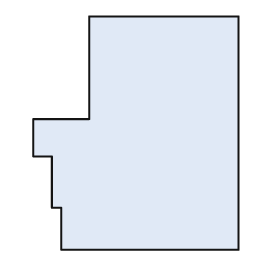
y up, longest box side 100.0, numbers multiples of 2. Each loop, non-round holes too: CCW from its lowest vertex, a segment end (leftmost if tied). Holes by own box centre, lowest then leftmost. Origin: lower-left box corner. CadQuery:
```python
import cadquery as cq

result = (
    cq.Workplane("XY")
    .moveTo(12.0, 0.0)
    .lineTo(88.0, 0.0)
    .lineTo(88.0, 100.0)
    .lineTo(24.0, 100.0)
    .lineTo(24.0, 56.0)
    .lineTo(0.0, 56.0)
    .lineTo(0.0, 40.0)
    .lineTo(8.0, 40.0)
    .lineTo(8.0, 18.0)
    .lineTo(12.0, 18.0)
    .close()
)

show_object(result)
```